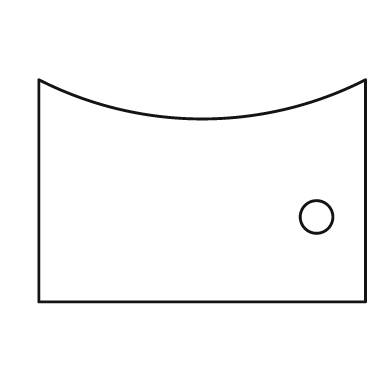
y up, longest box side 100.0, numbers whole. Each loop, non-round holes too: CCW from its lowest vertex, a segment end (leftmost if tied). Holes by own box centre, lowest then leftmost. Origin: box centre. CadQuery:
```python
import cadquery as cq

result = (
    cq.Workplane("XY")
    .moveTo(-50.0, -34.0)
    .lineTo(50.0, -34.0)
    .lineTo(50.0, 34.0)
    .threePointArc((0.0, 22.0), (-50.0, 34.0))
    .close()
    .moveTo(35.0, -8.0)
    .circle(5.0)
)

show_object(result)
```